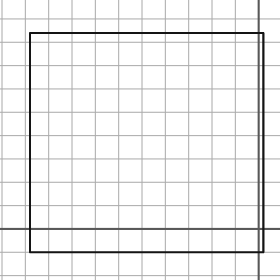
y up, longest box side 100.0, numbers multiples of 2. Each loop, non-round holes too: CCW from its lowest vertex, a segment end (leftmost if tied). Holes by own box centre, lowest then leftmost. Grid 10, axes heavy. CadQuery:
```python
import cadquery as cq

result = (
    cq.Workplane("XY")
    .moveTo(-98.0, -10.0)
    .lineTo(2.0, -10.0)
    .lineTo(2.0, 84.0)
    .lineTo(-98.0, 84.0)
    .close()
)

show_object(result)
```